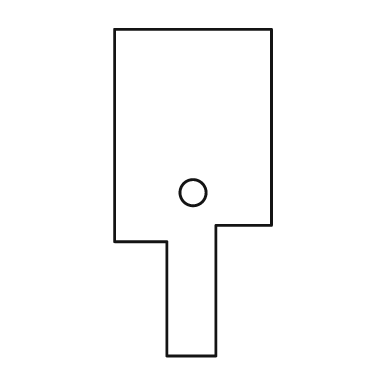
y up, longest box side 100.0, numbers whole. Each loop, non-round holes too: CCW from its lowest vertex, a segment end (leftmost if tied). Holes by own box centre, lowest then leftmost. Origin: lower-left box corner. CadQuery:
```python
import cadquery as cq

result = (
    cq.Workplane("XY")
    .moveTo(16.0, 0.0)
    .lineTo(31.0, 0.0)
    .lineTo(31.0, 40.0)
    .lineTo(48.0, 40.0)
    .lineTo(48.0, 100.0)
    .lineTo(0.0, 100.0)
    .lineTo(0.0, 35.0)
    .lineTo(16.0, 35.0)
    .close()
    .moveTo(24.0, 50.0)
    .circle(4.0)
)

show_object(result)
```